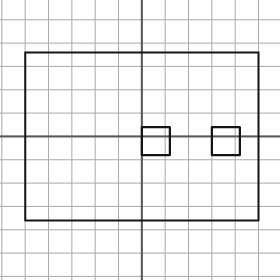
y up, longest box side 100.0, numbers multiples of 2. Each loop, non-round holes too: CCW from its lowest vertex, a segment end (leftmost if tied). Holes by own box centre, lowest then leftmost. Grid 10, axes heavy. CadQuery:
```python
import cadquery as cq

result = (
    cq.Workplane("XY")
    .moveTo(-50.0, -36.0)
    .lineTo(50.0, -36.0)
    .lineTo(50.0, 36.0)
    .lineTo(-50.0, 36.0)
    .close()
    .moveTo(0.0, -8.0)
    .lineTo(12.0, -8.0)
    .lineTo(12.0, 4.0)
    .lineTo(0.0, 4.0)
    .close()
    .moveTo(30.0, -8.0)
    .lineTo(42.0, -8.0)
    .lineTo(42.0, 4.0)
    .lineTo(30.0, 4.0)
    .close()
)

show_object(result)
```